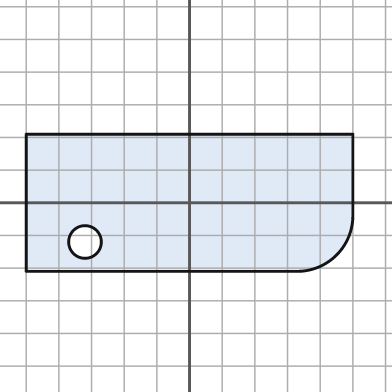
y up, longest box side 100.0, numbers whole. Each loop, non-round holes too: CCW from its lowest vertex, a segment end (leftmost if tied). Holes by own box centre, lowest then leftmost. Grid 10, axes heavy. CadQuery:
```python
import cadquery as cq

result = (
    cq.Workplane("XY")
    .moveTo(-50.0, -21.0)
    .lineTo(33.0, -21.0)
    .threePointArc((45.0, -16.0), (50.0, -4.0))
    .lineTo(50.0, 21.0)
    .lineTo(-50.0, 21.0)
    .close()
    .moveTo(-32.0, -12.0)
    .circle(5.0)
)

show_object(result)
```